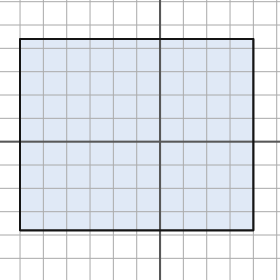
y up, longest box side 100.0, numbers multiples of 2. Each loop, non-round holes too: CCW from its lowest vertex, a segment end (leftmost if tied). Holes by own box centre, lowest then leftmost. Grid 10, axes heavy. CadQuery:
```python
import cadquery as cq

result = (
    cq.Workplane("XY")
    .moveTo(-60.0, -38.0)
    .lineTo(40.0, -38.0)
    .lineTo(40.0, 44.0)
    .lineTo(-60.0, 44.0)
    .close()
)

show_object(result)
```